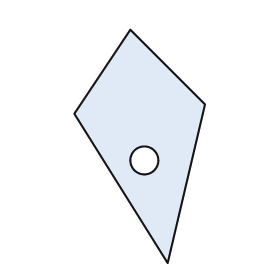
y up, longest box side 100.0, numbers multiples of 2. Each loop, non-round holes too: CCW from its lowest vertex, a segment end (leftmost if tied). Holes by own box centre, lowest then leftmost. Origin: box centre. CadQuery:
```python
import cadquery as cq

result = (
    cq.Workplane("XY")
    .moveTo(12.0, -50.0)
    .lineTo(28.0, 18.0)
    .lineTo(-4.0, 50.0)
    .lineTo(-28.0, 14.0)
    .close()
    .moveTo(2.0, -6.0)
    .circle(6.0)
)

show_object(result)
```